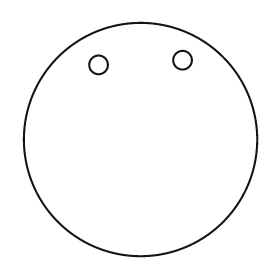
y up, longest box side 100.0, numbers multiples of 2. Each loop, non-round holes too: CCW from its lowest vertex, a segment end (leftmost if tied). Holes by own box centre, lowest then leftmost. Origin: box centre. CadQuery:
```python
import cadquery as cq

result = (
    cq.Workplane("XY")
    .moveTo(0.0, 0.0)
    .circle(50.0)
    .moveTo(-18.0, 32.0)
    .circle(4.0)
    .moveTo(18.0, 34.0)
    .circle(4.0)
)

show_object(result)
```